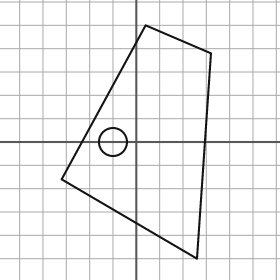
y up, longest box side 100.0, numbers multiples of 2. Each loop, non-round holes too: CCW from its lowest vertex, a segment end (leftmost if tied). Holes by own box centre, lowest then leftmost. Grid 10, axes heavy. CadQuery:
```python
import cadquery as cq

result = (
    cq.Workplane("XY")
    .moveTo(26.0, -50.0)
    .lineTo(32.0, 38.0)
    .lineTo(4.0, 50.0)
    .lineTo(-32.0, -16.0)
    .close()
    .moveTo(-10.0, 0.0)
    .circle(6.0)
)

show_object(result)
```